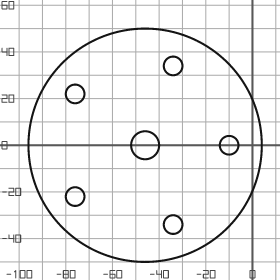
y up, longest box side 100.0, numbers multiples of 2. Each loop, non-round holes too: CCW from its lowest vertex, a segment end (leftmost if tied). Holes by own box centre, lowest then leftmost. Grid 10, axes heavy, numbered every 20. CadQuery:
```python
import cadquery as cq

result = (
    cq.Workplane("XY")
    .moveTo(-46.0, 0.0)
    .circle(50.0)
    .moveTo(-34.0, -34.0)
    .circle(4.0)
    .moveTo(-76.0, -22.0)
    .circle(4.0)
    .moveTo(-46.0, 0.0)
    .circle(6.0)
    .moveTo(-10.0, 0.0)
    .circle(4.0)
    .moveTo(-76.0, 22.0)
    .circle(4.0)
    .moveTo(-34.0, 34.0)
    .circle(4.0)
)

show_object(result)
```